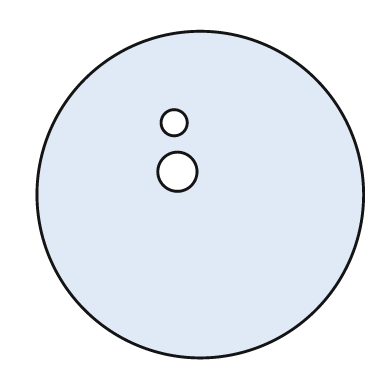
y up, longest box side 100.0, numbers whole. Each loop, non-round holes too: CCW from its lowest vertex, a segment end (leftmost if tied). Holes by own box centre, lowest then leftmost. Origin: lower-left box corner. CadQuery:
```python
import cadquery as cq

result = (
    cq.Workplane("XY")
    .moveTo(50.0, 50.0)
    .circle(50.0)
    .moveTo(43.0, 57.0)
    .circle(6.0)
    .moveTo(42.0, 72.0)
    .circle(4.0)
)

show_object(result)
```